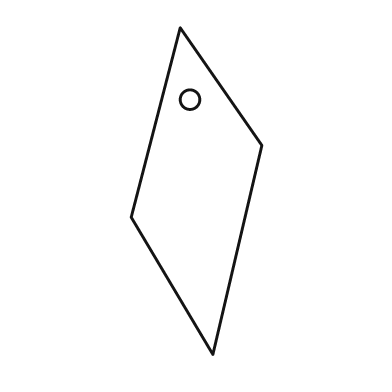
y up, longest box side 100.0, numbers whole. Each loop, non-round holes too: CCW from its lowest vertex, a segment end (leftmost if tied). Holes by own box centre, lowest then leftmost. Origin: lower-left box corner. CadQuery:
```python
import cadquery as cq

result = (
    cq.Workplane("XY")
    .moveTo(25.0, 0.0)
    .lineTo(40.0, 64.0)
    .lineTo(15.0, 100.0)
    .lineTo(0.0, 42.0)
    .close()
    .moveTo(18.0, 78.0)
    .circle(3.0)
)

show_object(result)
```